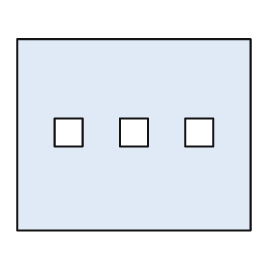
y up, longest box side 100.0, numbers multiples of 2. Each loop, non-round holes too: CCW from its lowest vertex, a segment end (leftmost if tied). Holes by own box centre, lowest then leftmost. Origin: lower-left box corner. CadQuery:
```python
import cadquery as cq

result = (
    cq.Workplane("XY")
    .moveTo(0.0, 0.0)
    .lineTo(100.0, 0.0)
    .lineTo(100.0, 82.0)
    .lineTo(0.0, 82.0)
    .close()
    .moveTo(16.0, 36.0)
    .lineTo(28.0, 36.0)
    .lineTo(28.0, 48.0)
    .lineTo(16.0, 48.0)
    .close()
    .moveTo(44.0, 36.0)
    .lineTo(56.0, 36.0)
    .lineTo(56.0, 48.0)
    .lineTo(44.0, 48.0)
    .close()
    .moveTo(72.0, 36.0)
    .lineTo(84.0, 36.0)
    .lineTo(84.0, 48.0)
    .lineTo(72.0, 48.0)
    .close()
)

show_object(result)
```